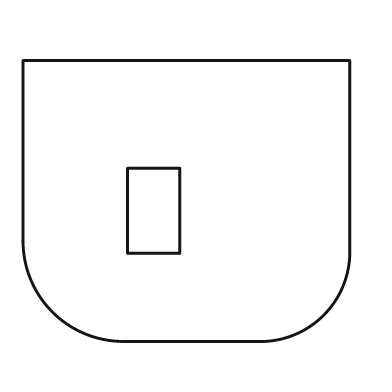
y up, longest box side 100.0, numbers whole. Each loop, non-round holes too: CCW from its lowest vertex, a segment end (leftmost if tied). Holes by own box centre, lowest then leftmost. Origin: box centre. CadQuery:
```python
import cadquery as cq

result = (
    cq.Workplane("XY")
    .moveTo(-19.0, -43.0)
    .lineTo(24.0, -43.0)
    .threePointArc((42.0, -35.0), (50.0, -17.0))
    .lineTo(50.0, 43.0)
    .lineTo(-50.0, 43.0)
    .lineTo(-50.0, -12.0)
    .threePointArc((-41.0, -34.0), (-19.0, -43.0))
    .close()
    .moveTo(-18.0, -16.0)
    .lineTo(-2.0, -16.0)
    .lineTo(-2.0, 10.0)
    .lineTo(-18.0, 10.0)
    .close()
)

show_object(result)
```